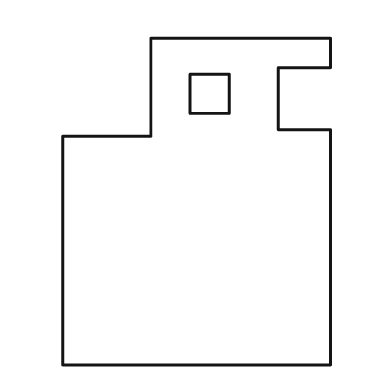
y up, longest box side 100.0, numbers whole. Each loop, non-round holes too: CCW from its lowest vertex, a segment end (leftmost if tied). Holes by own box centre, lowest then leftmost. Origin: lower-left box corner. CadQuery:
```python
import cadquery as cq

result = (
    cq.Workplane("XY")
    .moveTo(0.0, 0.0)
    .lineTo(82.0, 0.0)
    .lineTo(82.0, 72.0)
    .lineTo(66.0, 72.0)
    .lineTo(66.0, 91.0)
    .lineTo(82.0, 91.0)
    .lineTo(82.0, 100.0)
    .lineTo(27.0, 100.0)
    .lineTo(27.0, 70.0)
    .lineTo(0.0, 70.0)
    .close()
    .moveTo(39.0, 77.0)
    .lineTo(51.0, 77.0)
    .lineTo(51.0, 89.0)
    .lineTo(39.0, 89.0)
    .close()
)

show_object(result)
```